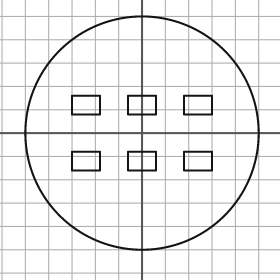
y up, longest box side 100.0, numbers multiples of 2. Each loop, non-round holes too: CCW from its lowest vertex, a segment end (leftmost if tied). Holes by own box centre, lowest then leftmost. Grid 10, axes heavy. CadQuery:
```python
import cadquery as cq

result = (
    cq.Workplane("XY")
    .moveTo(0.0, 0.0)
    .circle(50.0)
    .moveTo(-30.0, -16.0)
    .lineTo(-18.0, -16.0)
    .lineTo(-18.0, -8.0)
    .lineTo(-30.0, -8.0)
    .close()
    .moveTo(-6.0, -16.0)
    .lineTo(6.0, -16.0)
    .lineTo(6.0, -8.0)
    .lineTo(-6.0, -8.0)
    .close()
    .moveTo(18.0, -16.0)
    .lineTo(30.0, -16.0)
    .lineTo(30.0, -8.0)
    .lineTo(18.0, -8.0)
    .close()
    .moveTo(-30.0, 8.0)
    .lineTo(-18.0, 8.0)
    .lineTo(-18.0, 16.0)
    .lineTo(-30.0, 16.0)
    .close()
    .moveTo(-6.0, 8.0)
    .lineTo(6.0, 8.0)
    .lineTo(6.0, 16.0)
    .lineTo(-6.0, 16.0)
    .close()
    .moveTo(18.0, 8.0)
    .lineTo(30.0, 8.0)
    .lineTo(30.0, 16.0)
    .lineTo(18.0, 16.0)
    .close()
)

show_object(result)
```